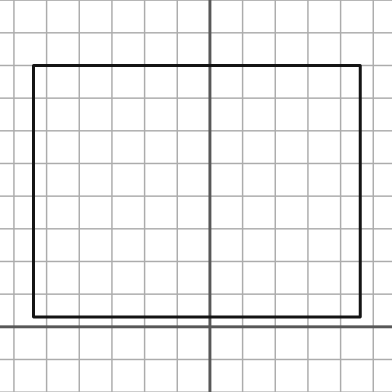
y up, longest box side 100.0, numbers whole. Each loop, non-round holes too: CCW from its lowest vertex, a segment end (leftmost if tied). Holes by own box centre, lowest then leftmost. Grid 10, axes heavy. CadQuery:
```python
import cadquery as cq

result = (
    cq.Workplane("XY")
    .moveTo(-54.0, 3.0)
    .lineTo(46.0, 3.0)
    .lineTo(46.0, 80.0)
    .lineTo(-54.0, 80.0)
    .close()
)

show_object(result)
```